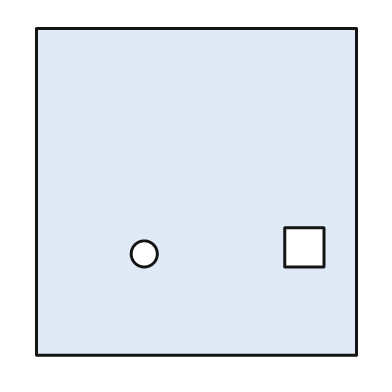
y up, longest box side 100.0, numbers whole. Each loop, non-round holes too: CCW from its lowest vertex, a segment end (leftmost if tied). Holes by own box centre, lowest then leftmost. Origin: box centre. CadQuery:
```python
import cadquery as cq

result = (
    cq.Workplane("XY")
    .moveTo(-49.0, -50.0)
    .lineTo(49.0, -50.0)
    .lineTo(49.0, 50.0)
    .lineTo(-49.0, 50.0)
    .close()
    .moveTo(-16.0, -19.0)
    .circle(4.0)
    .moveTo(27.0, -23.0)
    .lineTo(39.0, -23.0)
    .lineTo(39.0, -11.0)
    .lineTo(27.0, -11.0)
    .close()
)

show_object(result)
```